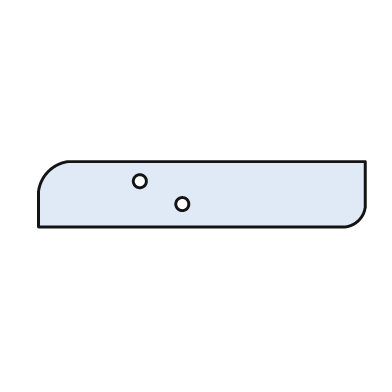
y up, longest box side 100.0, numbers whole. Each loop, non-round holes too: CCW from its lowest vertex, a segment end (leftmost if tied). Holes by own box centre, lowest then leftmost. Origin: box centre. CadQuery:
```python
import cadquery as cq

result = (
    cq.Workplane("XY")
    .moveTo(-50.0, -10.0)
    .lineTo(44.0, -10.0)
    .threePointArc((48.0, -8.0), (50.0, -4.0))
    .lineTo(50.0, 10.0)
    .lineTo(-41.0, 10.0)
    .threePointArc((-47.0, 7.0), (-50.0, 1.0))
    .close()
    .moveTo(-6.0, -3.0)
    .circle(2.0)
    .moveTo(-19.0, 4.0)
    .circle(2.0)
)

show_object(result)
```